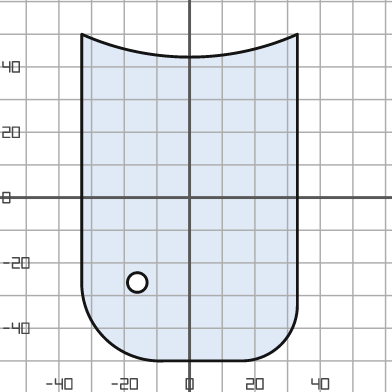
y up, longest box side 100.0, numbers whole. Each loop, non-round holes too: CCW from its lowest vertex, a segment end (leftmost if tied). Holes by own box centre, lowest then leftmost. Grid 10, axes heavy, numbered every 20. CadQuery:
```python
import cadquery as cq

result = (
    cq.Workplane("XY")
    .moveTo(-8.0, -50.0)
    .lineTo(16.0, -50.0)
    .threePointArc((28.0, -45.0), (33.0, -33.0))
    .lineTo(33.0, 50.0)
    .threePointArc((0.0, 43.0), (-33.0, 50.0))
    .lineTo(-33.0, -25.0)
    .threePointArc((-26.0, -43.0), (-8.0, -50.0))
    .close()
    .moveTo(-16.0, -26.0)
    .circle(3.0)
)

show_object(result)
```